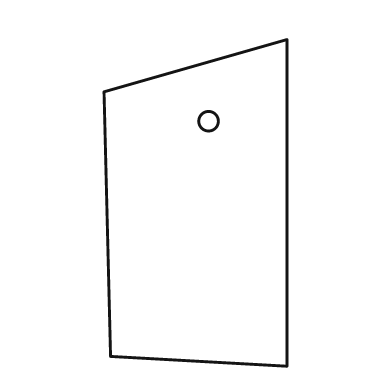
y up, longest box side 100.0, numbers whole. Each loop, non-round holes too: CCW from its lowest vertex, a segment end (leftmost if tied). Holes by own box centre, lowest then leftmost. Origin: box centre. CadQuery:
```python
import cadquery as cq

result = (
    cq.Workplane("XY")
    .moveTo(28.0, -50.0)
    .lineTo(28.0, 50.0)
    .lineTo(-28.0, 34.0)
    .lineTo(-26.0, -47.0)
    .close()
    .moveTo(4.0, 25.0)
    .circle(3.0)
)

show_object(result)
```